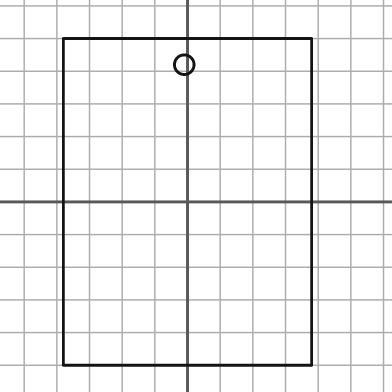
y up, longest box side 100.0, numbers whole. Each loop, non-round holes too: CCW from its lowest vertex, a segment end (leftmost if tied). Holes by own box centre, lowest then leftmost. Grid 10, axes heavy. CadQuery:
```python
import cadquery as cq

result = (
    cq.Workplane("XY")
    .moveTo(-38.0, -50.0)
    .lineTo(38.0, -50.0)
    .lineTo(38.0, 50.0)
    .lineTo(-38.0, 50.0)
    .close()
    .moveTo(-1.0, 42.0)
    .circle(3.0)
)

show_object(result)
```